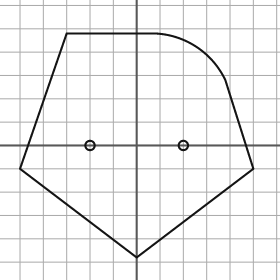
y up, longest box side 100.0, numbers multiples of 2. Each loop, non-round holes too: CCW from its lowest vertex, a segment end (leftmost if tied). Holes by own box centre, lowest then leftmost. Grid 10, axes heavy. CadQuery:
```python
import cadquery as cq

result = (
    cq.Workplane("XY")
    .moveTo(0.0, -48.0)
    .lineTo(50.0, -10.0)
    .lineTo(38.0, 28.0)
    .threePointArc((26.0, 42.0), (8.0, 48.0))
    .lineTo(-30.0, 48.0)
    .lineTo(-50.0, -10.0)
    .close()
    .moveTo(-20.0, 0.0)
    .circle(2.0)
    .moveTo(20.0, 0.0)
    .circle(2.0)
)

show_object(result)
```